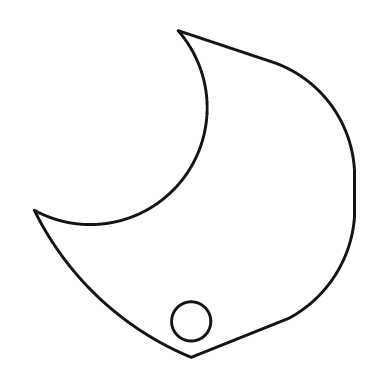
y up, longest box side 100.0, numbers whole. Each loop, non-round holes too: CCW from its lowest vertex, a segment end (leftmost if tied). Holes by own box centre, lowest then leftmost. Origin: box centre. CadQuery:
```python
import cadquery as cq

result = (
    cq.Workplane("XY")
    .moveTo(-1.0, -50.0)
    .lineTo(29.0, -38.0)
    .threePointArc((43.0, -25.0), (49.0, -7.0))
    .lineTo(49.0, 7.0)
    .threePointArc((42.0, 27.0), (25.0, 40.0))
    .lineTo(-5.0, 50.0)
    .threePointArc((-4.0, 4.0), (-49.0, -5.0))
    .threePointArc((-29.0, -32.0), (-1.0, -50.0))
    .close()
    .moveTo(-1.0, -39.0)
    .circle(6.0)
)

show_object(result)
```